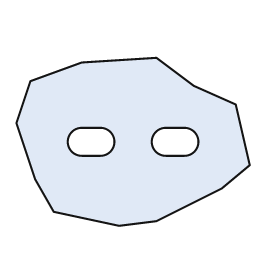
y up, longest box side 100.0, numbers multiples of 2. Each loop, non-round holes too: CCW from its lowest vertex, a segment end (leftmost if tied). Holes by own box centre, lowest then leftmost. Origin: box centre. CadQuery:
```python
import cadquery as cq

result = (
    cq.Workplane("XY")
    .moveTo(-6.0, -36.0)
    .lineTo(10.0, -34.0)
    .lineTo(38.0, -20.0)
    .lineTo(50.0, -10.0)
    .lineTo(44.0, 16.0)
    .lineTo(26.0, 24.0)
    .lineTo(10.0, 36.0)
    .lineTo(-22.0, 34.0)
    .lineTo(-44.0, 26.0)
    .lineTo(-50.0, 8.0)
    .lineTo(-42.0, -16.0)
    .lineTo(-34.0, -30.0)
    .close()
    .moveTo(-22.0, -6.0)
    .lineTo(-14.0, -6.0)
    .threePointArc((-8.0, 0.0), (-14.0, 6.0))
    .lineTo(-22.0, 6.0)
    .threePointArc((-28.0, 0.0), (-22.0, -6.0))
    .close()
    .moveTo(14.0, -6.0)
    .lineTo(22.0, -6.0)
    .threePointArc((28.0, 0.0), (22.0, 6.0))
    .lineTo(14.0, 6.0)
    .threePointArc((8.0, 0.0), (14.0, -6.0))
    .close()
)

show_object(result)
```